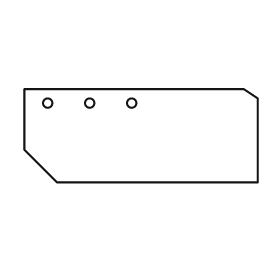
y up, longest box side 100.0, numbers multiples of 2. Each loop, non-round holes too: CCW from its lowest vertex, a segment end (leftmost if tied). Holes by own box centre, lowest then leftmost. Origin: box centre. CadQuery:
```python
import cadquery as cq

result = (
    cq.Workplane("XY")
    .moveTo(-36.0, -20.0)
    .lineTo(50.0, -20.0)
    .lineTo(50.0, 16.0)
    .lineTo(44.0, 20.0)
    .lineTo(-50.0, 20.0)
    .lineTo(-50.0, -6.0)
    .close()
    .moveTo(-40.0, 14.0)
    .circle(2.0)
    .moveTo(-22.0, 14.0)
    .circle(2.0)
    .moveTo(-4.0, 14.0)
    .circle(2.0)
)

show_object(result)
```